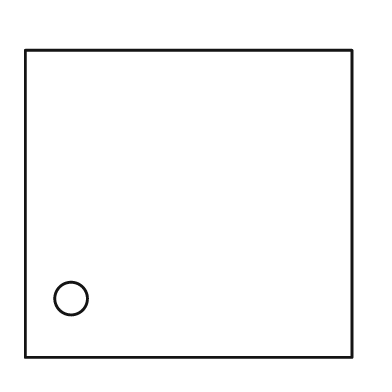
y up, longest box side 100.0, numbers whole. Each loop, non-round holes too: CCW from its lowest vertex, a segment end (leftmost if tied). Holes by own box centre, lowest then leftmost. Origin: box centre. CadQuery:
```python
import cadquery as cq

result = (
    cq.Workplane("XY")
    .moveTo(-50.0, -47.0)
    .lineTo(50.0, -47.0)
    .lineTo(50.0, 47.0)
    .lineTo(-50.0, 47.0)
    .close()
    .moveTo(-36.0, -29.0)
    .circle(5.0)
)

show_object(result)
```